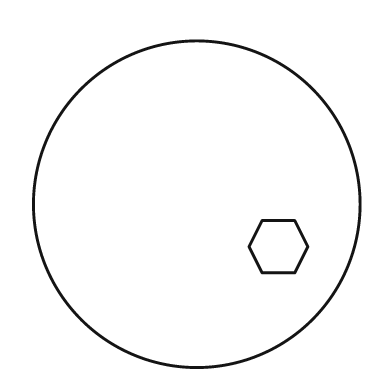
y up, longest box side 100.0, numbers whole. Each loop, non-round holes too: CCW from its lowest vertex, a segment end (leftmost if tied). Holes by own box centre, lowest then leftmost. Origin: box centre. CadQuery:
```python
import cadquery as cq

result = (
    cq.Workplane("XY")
    .moveTo(0.0, 0.0)
    .circle(50.0)
    .moveTo(20.0, -21.0)
    .lineTo(30.0, -21.0)
    .lineTo(34.0, -13.0)
    .lineTo(30.0, -5.0)
    .lineTo(20.0, -5.0)
    .lineTo(16.0, -13.0)
    .close()
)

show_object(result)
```